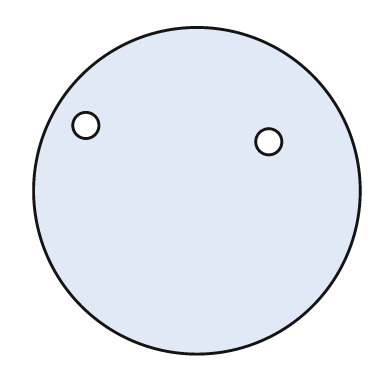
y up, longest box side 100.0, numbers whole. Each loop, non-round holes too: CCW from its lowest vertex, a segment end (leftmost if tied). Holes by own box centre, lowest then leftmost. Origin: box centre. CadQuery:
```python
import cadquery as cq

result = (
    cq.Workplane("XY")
    .moveTo(0.0, 0.0)
    .circle(50.0)
    .moveTo(22.0, 15.0)
    .circle(4.0)
    .moveTo(-34.0, 20.0)
    .circle(4.0)
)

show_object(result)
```